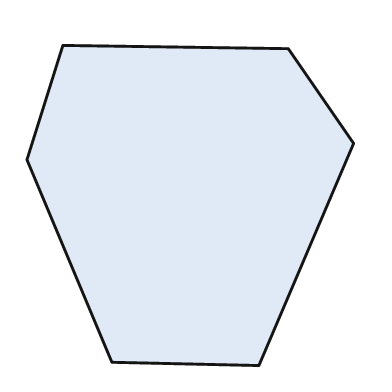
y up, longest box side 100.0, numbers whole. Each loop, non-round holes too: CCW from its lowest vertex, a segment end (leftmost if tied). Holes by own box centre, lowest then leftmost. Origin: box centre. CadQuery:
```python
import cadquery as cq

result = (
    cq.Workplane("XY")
    .moveTo(21.0, -49.0)
    .lineTo(50.0, 19.0)
    .lineTo(30.0, 48.0)
    .lineTo(-39.0, 49.0)
    .lineTo(-50.0, 14.0)
    .lineTo(-24.0, -48.0)
    .close()
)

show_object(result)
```